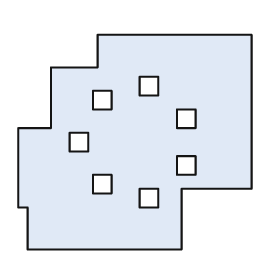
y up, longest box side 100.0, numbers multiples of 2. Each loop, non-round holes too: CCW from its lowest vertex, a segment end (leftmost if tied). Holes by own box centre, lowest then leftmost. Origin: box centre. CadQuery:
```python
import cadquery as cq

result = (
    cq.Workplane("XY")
    .moveTo(-46.0, -46.0)
    .lineTo(20.0, -46.0)
    .lineTo(20.0, -20.0)
    .lineTo(50.0, -20.0)
    .lineTo(50.0, 46.0)
    .lineTo(-16.0, 46.0)
    .lineTo(-16.0, 32.0)
    .lineTo(-36.0, 32.0)
    .lineTo(-36.0, 6.0)
    .lineTo(-50.0, 6.0)
    .lineTo(-50.0, -28.0)
    .lineTo(-46.0, -28.0)
    .close()
    .moveTo(2.0, -28.0)
    .lineTo(10.0, -28.0)
    .lineTo(10.0, -20.0)
    .lineTo(2.0, -20.0)
    .close()
    .moveTo(-18.0, -22.0)
    .lineTo(-10.0, -22.0)
    .lineTo(-10.0, -14.0)
    .lineTo(-18.0, -14.0)
    .close()
    .moveTo(18.0, -14.0)
    .lineTo(26.0, -14.0)
    .lineTo(26.0, -6.0)
    .lineTo(18.0, -6.0)
    .close()
    .moveTo(-28.0, -4.0)
    .lineTo(-20.0, -4.0)
    .lineTo(-20.0, 4.0)
    .lineTo(-28.0, 4.0)
    .close()
    .moveTo(18.0, 6.0)
    .lineTo(26.0, 6.0)
    .lineTo(26.0, 14.0)
    .lineTo(18.0, 14.0)
    .close()
    .moveTo(-18.0, 14.0)
    .lineTo(-10.0, 14.0)
    .lineTo(-10.0, 22.0)
    .lineTo(-18.0, 22.0)
    .close()
    .moveTo(2.0, 20.0)
    .lineTo(10.0, 20.0)
    .lineTo(10.0, 28.0)
    .lineTo(2.0, 28.0)
    .close()
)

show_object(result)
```